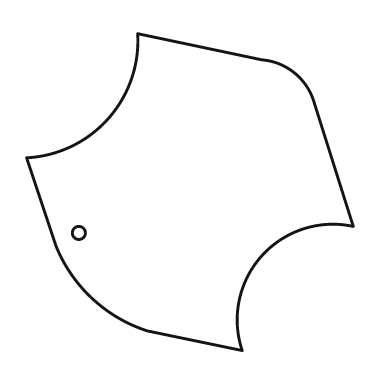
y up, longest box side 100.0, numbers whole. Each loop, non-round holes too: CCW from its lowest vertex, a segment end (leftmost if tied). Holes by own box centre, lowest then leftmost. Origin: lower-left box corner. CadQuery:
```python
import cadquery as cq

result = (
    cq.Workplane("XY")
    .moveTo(66.0, 0.0)
    .threePointArc((72.0, 29.0), (100.0, 38.0))
    .lineTo(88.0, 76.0)
    .threePointArc((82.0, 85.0), (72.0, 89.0))
    .lineTo(34.0, 97.0)
    .threePointArc((25.0, 71.0), (0.0, 59.0))
    .lineTo(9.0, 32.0)
    .threePointArc((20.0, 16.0), (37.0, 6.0))
    .close()
    .moveTo(16.0, 36.0)
    .circle(2.0)
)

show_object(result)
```